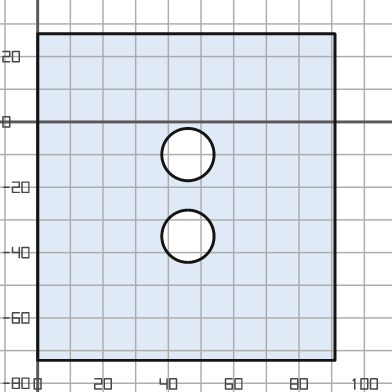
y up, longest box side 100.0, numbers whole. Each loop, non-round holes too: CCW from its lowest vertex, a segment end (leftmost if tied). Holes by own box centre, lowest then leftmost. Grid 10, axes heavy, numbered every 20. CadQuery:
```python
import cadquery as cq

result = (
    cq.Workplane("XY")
    .moveTo(0.0, -73.0)
    .lineTo(91.0, -73.0)
    .lineTo(91.0, 27.0)
    .lineTo(0.0, 27.0)
    .close()
    .moveTo(46.0, -35.0)
    .circle(8.0)
    .moveTo(46.0, -10.0)
    .circle(8.0)
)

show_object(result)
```